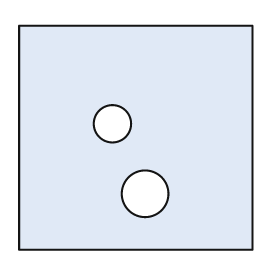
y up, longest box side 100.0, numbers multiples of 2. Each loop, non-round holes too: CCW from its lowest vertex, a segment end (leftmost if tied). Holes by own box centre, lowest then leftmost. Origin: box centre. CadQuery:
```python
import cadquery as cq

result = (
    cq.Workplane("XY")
    .moveTo(-50.0, -48.0)
    .lineTo(50.0, -48.0)
    .lineTo(50.0, 48.0)
    .lineTo(-50.0, 48.0)
    .close()
    .moveTo(4.0, -24.0)
    .circle(10.0)
    .moveTo(-10.0, 6.0)
    .circle(8.0)
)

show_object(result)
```